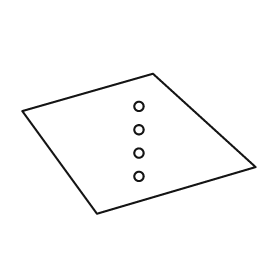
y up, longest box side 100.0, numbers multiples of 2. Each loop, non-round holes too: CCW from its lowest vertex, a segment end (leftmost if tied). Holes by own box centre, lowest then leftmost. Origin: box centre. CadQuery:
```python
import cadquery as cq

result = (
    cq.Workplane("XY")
    .moveTo(-18.0, -30.0)
    .lineTo(50.0, -10.0)
    .lineTo(6.0, 30.0)
    .lineTo(-50.0, 14.0)
    .close()
    .moveTo(0.0, -14.0)
    .circle(2.0)
    .moveTo(0.0, -4.0)
    .circle(2.0)
    .moveTo(0.0, 6.0)
    .circle(2.0)
    .moveTo(0.0, 16.0)
    .circle(2.0)
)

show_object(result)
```